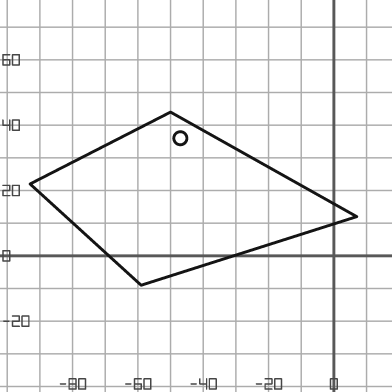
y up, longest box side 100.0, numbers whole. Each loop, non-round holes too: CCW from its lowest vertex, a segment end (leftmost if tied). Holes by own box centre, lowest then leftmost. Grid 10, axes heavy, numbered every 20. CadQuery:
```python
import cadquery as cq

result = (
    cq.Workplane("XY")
    .moveTo(-59.0, -9.0)
    .lineTo(7.0, 12.0)
    .lineTo(-50.0, 44.0)
    .lineTo(-93.0, 22.0)
    .close()
    .moveTo(-47.0, 36.0)
    .circle(2.0)
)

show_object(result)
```